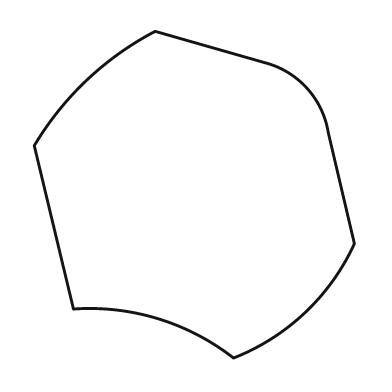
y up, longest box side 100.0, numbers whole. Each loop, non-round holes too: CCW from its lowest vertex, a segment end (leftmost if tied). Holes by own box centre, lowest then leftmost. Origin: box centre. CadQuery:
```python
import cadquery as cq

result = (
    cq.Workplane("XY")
    .moveTo(12.0, -50.0)
    .threePointArc((34.0, -36.0), (49.0, -15.0))
    .lineTo(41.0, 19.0)
    .threePointArc((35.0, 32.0), (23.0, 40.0))
    .lineTo(-12.0, 50.0)
    .threePointArc((-33.0, 35.0), (-49.0, 15.0))
    .lineTo(-37.0, -35.0)
    .threePointArc((-11.0, -38.0), (12.0, -50.0))
    .close()
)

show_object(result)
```